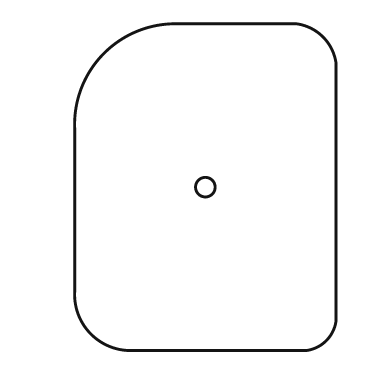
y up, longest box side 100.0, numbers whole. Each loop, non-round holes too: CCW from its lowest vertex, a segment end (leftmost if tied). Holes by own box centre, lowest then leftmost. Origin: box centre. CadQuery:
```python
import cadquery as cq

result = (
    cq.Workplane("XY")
    .moveTo(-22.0, -50.0)
    .lineTo(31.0, -50.0)
    .threePointArc((37.0, -47.0), (40.0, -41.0))
    .lineTo(40.0, 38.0)
    .threePointArc((36.0, 46.0), (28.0, 50.0))
    .lineTo(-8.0, 50.0)
    .threePointArc((-31.0, 41.0), (-40.0, 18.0))
    .lineTo(-40.0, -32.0)
    .threePointArc((-35.0, -45.0), (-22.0, -50.0))
    .close()
    .moveTo(0.0, 0.0)
    .circle(3.0)
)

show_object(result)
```